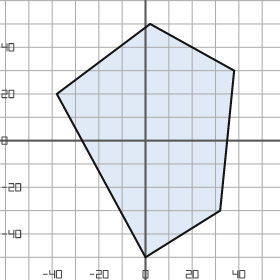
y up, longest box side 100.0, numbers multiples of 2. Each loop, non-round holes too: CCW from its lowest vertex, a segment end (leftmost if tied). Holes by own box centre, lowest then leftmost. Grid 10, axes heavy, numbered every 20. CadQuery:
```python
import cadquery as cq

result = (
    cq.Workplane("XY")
    .moveTo(0.0, -50.0)
    .lineTo(32.0, -30.0)
    .lineTo(38.0, 30.0)
    .lineTo(2.0, 50.0)
    .lineTo(-38.0, 20.0)
    .close()
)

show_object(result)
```